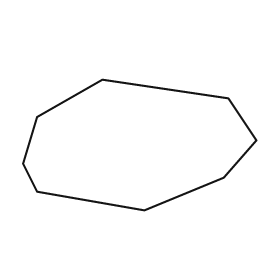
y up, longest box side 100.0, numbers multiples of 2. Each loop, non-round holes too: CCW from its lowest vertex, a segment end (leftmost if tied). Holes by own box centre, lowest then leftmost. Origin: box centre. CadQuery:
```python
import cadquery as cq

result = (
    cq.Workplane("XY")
    .moveTo(2.0, -28.0)
    .lineTo(36.0, -14.0)
    .lineTo(50.0, 2.0)
    .lineTo(38.0, 20.0)
    .lineTo(-16.0, 28.0)
    .lineTo(-44.0, 12.0)
    .lineTo(-50.0, -8.0)
    .lineTo(-44.0, -20.0)
    .close()
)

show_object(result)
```